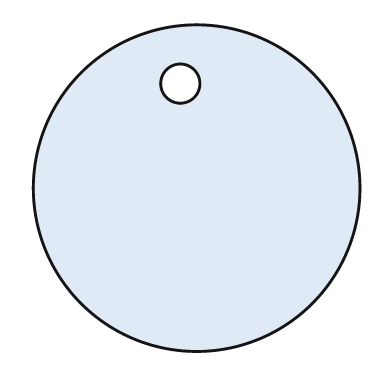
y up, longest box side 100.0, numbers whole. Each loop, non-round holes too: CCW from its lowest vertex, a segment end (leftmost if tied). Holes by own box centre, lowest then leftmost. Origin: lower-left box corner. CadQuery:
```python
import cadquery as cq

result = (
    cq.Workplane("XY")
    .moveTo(50.0, 50.0)
    .circle(50.0)
    .moveTo(45.0, 82.0)
    .circle(6.0)
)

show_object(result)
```